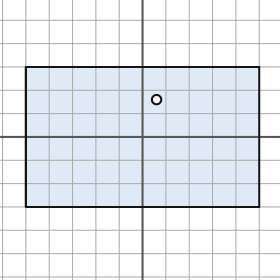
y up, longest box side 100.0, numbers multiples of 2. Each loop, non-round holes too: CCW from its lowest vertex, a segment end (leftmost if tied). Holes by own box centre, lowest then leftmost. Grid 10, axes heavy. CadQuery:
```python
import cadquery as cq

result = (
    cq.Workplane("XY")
    .moveTo(-50.0, -30.0)
    .lineTo(50.0, -30.0)
    .lineTo(50.0, 30.0)
    .lineTo(-50.0, 30.0)
    .close()
    .moveTo(6.0, 16.0)
    .circle(2.0)
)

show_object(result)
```